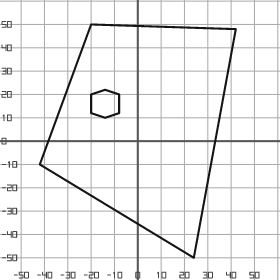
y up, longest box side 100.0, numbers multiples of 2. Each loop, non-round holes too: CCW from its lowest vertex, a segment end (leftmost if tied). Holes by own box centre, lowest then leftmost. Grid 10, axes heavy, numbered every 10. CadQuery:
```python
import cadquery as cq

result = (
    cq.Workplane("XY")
    .moveTo(24.0, -50.0)
    .lineTo(42.0, 48.0)
    .lineTo(-20.0, 50.0)
    .lineTo(-42.0, -10.0)
    .close()
    .moveTo(-14.0, 10.0)
    .lineTo(-8.0, 12.0)
    .lineTo(-8.0, 20.0)
    .lineTo(-14.0, 22.0)
    .lineTo(-20.0, 20.0)
    .lineTo(-20.0, 12.0)
    .close()
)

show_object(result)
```